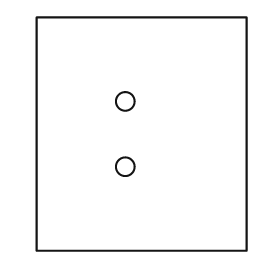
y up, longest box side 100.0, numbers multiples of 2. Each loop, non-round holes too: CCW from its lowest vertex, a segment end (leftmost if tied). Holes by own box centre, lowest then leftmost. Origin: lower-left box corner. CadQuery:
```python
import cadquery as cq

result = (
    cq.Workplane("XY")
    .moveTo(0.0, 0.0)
    .lineTo(90.0, 0.0)
    .lineTo(90.0, 100.0)
    .lineTo(0.0, 100.0)
    .close()
    .moveTo(38.0, 36.0)
    .circle(4.0)
    .moveTo(38.0, 64.0)
    .circle(4.0)
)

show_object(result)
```